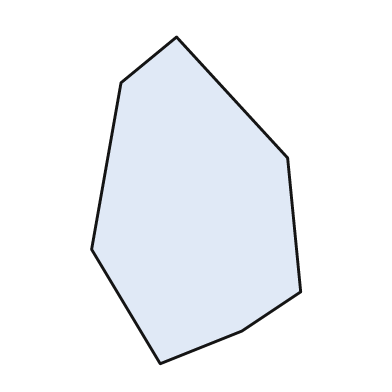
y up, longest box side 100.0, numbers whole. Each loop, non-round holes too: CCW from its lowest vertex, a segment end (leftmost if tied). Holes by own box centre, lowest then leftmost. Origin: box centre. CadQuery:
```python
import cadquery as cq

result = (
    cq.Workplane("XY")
    .moveTo(-11.0, -50.0)
    .lineTo(14.0, -40.0)
    .lineTo(32.0, -28.0)
    .lineTo(28.0, 13.0)
    .lineTo(-6.0, 50.0)
    .lineTo(-23.0, 36.0)
    .lineTo(-32.0, -15.0)
    .close()
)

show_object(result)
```